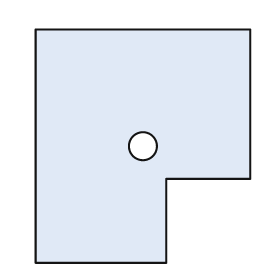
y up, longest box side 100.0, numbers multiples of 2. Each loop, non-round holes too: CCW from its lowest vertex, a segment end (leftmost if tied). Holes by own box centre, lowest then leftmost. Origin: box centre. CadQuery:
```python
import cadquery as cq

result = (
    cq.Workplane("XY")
    .moveTo(-46.0, -50.0)
    .lineTo(10.0, -50.0)
    .lineTo(10.0, -14.0)
    .lineTo(46.0, -14.0)
    .lineTo(46.0, 50.0)
    .lineTo(-46.0, 50.0)
    .close()
    .moveTo(0.0, 0.0)
    .circle(6.0)
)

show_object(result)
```